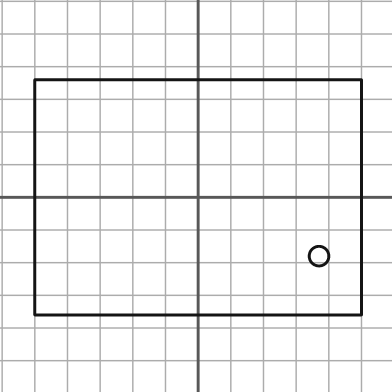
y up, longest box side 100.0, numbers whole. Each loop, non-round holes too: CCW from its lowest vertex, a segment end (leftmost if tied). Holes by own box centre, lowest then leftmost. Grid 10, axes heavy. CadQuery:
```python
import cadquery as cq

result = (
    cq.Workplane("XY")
    .moveTo(-50.0, -36.0)
    .lineTo(50.0, -36.0)
    .lineTo(50.0, 36.0)
    .lineTo(-50.0, 36.0)
    .close()
    .moveTo(37.0, -18.0)
    .circle(3.0)
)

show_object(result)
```